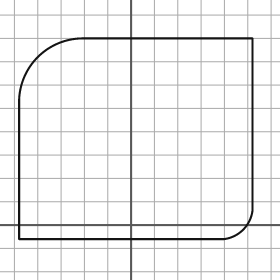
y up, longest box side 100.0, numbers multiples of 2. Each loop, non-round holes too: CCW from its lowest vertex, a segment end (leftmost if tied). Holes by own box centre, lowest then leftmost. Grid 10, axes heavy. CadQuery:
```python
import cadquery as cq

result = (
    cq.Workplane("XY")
    .moveTo(-48.0, -6.0)
    .lineTo(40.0, -6.0)
    .threePointArc((48.0, -2.0), (52.0, 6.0))
    .lineTo(52.0, 80.0)
    .lineTo(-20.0, 80.0)
    .threePointArc((-40.0, 72.0), (-48.0, 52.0))
    .close()
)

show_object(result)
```